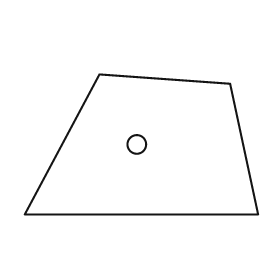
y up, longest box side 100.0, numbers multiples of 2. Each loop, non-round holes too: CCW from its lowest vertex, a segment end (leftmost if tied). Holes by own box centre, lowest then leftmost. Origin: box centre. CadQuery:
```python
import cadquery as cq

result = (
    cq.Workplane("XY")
    .moveTo(-50.0, -30.0)
    .lineTo(50.0, -30.0)
    .lineTo(38.0, 26.0)
    .lineTo(-18.0, 30.0)
    .close()
    .moveTo(-2.0, 0.0)
    .circle(4.0)
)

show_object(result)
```